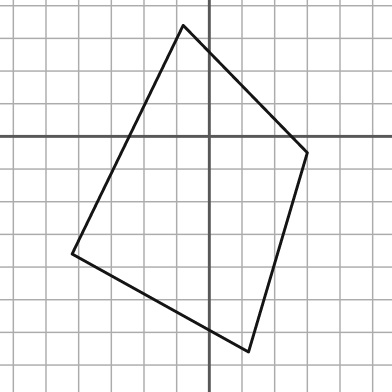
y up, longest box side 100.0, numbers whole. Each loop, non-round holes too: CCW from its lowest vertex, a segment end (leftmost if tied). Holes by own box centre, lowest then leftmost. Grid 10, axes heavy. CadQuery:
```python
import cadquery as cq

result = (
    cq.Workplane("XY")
    .moveTo(12.0, -66.0)
    .lineTo(30.0, -5.0)
    .lineTo(-8.0, 34.0)
    .lineTo(-42.0, -36.0)
    .close()
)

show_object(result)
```